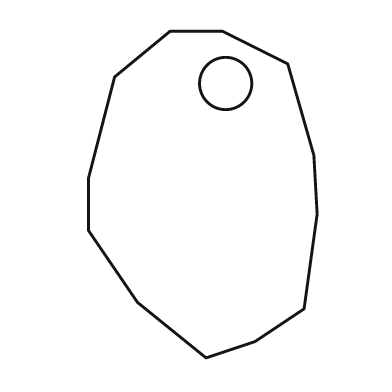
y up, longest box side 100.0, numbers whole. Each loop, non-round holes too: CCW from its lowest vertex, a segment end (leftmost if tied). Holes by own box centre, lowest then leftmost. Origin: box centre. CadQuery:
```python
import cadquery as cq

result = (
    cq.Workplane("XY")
    .moveTo(1.0, -50.0)
    .lineTo(16.0, -45.0)
    .lineTo(31.0, -35.0)
    .lineTo(35.0, -6.0)
    .lineTo(34.0, 12.0)
    .lineTo(26.0, 40.0)
    .lineTo(6.0, 50.0)
    .lineTo(-10.0, 50.0)
    .lineTo(-27.0, 36.0)
    .lineTo(-35.0, 5.0)
    .lineTo(-35.0, -11.0)
    .lineTo(-20.0, -33.0)
    .close()
    .moveTo(7.0, 34.0)
    .circle(8.0)
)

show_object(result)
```